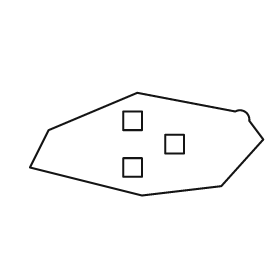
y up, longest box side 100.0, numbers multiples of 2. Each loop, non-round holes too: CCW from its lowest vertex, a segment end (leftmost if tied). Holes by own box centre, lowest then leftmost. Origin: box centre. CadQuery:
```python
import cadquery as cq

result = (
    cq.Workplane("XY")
    .moveTo(-2.0, -22.0)
    .lineTo(32.0, -18.0)
    .lineTo(50.0, 2.0)
    .lineTo(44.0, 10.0)
    .threePointArc((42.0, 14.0), (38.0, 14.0))
    .lineTo(-4.0, 22.0)
    .lineTo(-42.0, 6.0)
    .lineTo(-50.0, -10.0)
    .close()
    .moveTo(-10.0, -14.0)
    .lineTo(-2.0, -14.0)
    .lineTo(-2.0, -6.0)
    .lineTo(-10.0, -6.0)
    .close()
    .moveTo(8.0, -4.0)
    .lineTo(16.0, -4.0)
    .lineTo(16.0, 4.0)
    .lineTo(8.0, 4.0)
    .close()
    .moveTo(-10.0, 6.0)
    .lineTo(-2.0, 6.0)
    .lineTo(-2.0, 14.0)
    .lineTo(-10.0, 14.0)
    .close()
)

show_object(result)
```